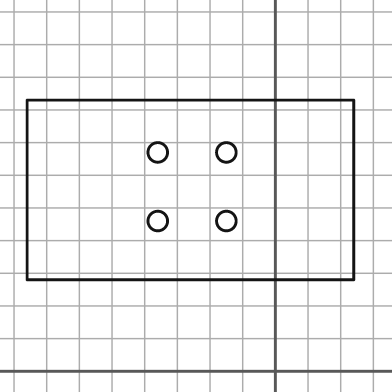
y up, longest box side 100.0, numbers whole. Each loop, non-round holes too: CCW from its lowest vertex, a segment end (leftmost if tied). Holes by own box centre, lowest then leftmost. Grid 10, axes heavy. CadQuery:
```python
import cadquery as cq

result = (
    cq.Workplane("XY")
    .moveTo(-76.0, 28.0)
    .lineTo(24.0, 28.0)
    .lineTo(24.0, 83.0)
    .lineTo(-76.0, 83.0)
    .close()
    .moveTo(-36.0, 46.0)
    .circle(3.0)
    .moveTo(-15.0, 46.0)
    .circle(3.0)
    .moveTo(-36.0, 67.0)
    .circle(3.0)
    .moveTo(-15.0, 67.0)
    .circle(3.0)
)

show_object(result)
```